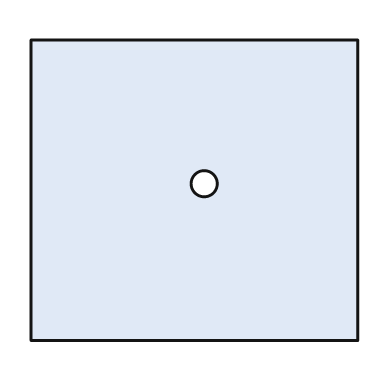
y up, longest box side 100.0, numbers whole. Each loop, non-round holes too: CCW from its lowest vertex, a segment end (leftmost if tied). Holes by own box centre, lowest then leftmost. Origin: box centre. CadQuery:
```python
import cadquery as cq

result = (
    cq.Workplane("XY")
    .moveTo(-50.0, -46.0)
    .lineTo(50.0, -46.0)
    .lineTo(50.0, 46.0)
    .lineTo(-50.0, 46.0)
    .close()
    .moveTo(3.0, 2.0)
    .circle(4.0)
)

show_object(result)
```